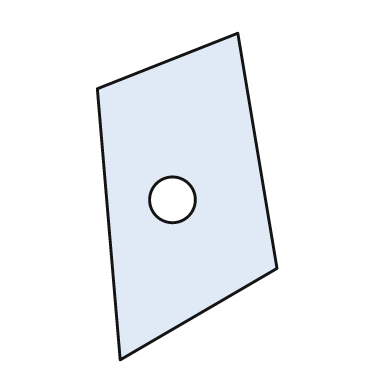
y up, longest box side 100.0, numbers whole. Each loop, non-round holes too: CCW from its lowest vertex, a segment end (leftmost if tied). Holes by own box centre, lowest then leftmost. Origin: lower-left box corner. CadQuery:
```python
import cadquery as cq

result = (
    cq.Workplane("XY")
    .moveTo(7.0, 0.0)
    .lineTo(55.0, 28.0)
    .lineTo(43.0, 100.0)
    .lineTo(0.0, 83.0)
    .close()
    .moveTo(23.0, 49.0)
    .circle(7.0)
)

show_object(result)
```